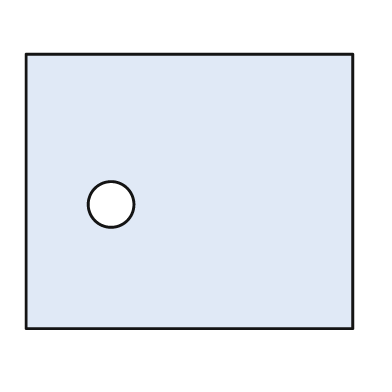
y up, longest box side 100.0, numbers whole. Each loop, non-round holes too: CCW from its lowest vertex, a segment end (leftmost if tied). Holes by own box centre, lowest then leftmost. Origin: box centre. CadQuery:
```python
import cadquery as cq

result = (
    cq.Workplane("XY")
    .moveTo(-50.0, -42.0)
    .lineTo(50.0, -42.0)
    .lineTo(50.0, 42.0)
    .lineTo(-50.0, 42.0)
    .close()
    .moveTo(-24.0, -4.0)
    .circle(7.0)
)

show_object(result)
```